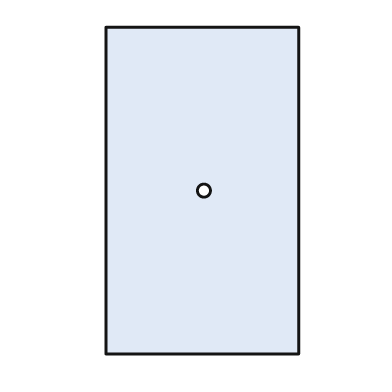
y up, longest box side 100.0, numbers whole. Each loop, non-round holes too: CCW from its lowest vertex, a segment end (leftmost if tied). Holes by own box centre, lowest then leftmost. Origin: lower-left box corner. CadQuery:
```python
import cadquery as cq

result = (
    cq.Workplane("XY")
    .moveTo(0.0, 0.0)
    .lineTo(59.0, 0.0)
    .lineTo(59.0, 100.0)
    .lineTo(0.0, 100.0)
    .close()
    .moveTo(30.0, 50.0)
    .circle(2.0)
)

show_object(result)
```